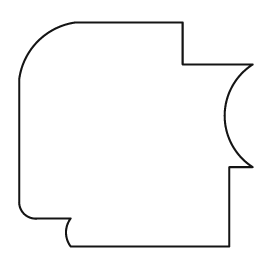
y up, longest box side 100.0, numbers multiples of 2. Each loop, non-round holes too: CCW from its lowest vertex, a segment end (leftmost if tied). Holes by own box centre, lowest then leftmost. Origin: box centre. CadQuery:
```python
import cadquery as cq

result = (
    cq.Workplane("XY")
    .moveTo(-28.0, -48.0)
    .lineTo(40.0, -48.0)
    .lineTo(40.0, -14.0)
    .lineTo(50.0, -14.0)
    .threePointArc((38.0, 8.0), (50.0, 30.0))
    .lineTo(20.0, 30.0)
    .lineTo(20.0, 48.0)
    .lineTo(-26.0, 48.0)
    .threePointArc((-42.0, 40.0), (-50.0, 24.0))
    .lineTo(-50.0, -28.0)
    .threePointArc((-48.0, -34.0), (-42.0, -36.0))
    .lineTo(-28.0, -36.0)
    .threePointArc((-30.0, -42.0), (-28.0, -48.0))
    .close()
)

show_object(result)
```